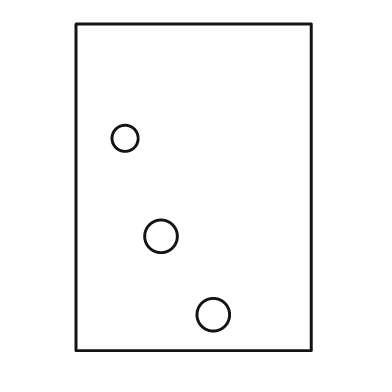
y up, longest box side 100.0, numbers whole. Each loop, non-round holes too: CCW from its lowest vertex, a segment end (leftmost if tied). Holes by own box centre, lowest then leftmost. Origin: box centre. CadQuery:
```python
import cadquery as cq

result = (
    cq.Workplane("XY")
    .moveTo(-36.0, -50.0)
    .lineTo(36.0, -50.0)
    .lineTo(36.0, 50.0)
    .lineTo(-36.0, 50.0)
    .close()
    .moveTo(6.0, -39.0)
    .circle(5.0)
    .moveTo(-10.0, -15.0)
    .circle(5.0)
    .moveTo(-21.0, 15.0)
    .circle(4.0)
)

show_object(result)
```